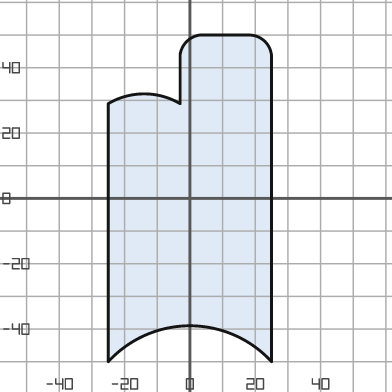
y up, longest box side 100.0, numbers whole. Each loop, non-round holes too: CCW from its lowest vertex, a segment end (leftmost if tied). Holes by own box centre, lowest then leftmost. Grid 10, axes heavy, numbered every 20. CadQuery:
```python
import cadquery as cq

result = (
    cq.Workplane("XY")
    .moveTo(-25.0, -50.0)
    .threePointArc((0.0, -39.0), (25.0, -50.0))
    .lineTo(25.0, 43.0)
    .threePointArc((23.0, 48.0), (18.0, 50.0))
    .lineTo(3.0, 50.0)
    .threePointArc((-1.0, 48.0), (-3.0, 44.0))
    .lineTo(-3.0, 29.0)
    .threePointArc((-14.0, 32.0), (-25.0, 29.0))
    .close()
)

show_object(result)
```